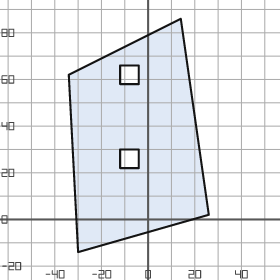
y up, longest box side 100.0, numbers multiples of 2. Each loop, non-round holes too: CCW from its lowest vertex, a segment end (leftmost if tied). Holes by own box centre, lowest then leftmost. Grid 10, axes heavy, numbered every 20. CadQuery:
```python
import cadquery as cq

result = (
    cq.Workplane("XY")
    .moveTo(-30.0, -14.0)
    .lineTo(26.0, 2.0)
    .lineTo(14.0, 86.0)
    .lineTo(-34.0, 62.0)
    .close()
    .moveTo(-12.0, 22.0)
    .lineTo(-4.0, 22.0)
    .lineTo(-4.0, 30.0)
    .lineTo(-12.0, 30.0)
    .close()
    .moveTo(-12.0, 58.0)
    .lineTo(-4.0, 58.0)
    .lineTo(-4.0, 66.0)
    .lineTo(-12.0, 66.0)
    .close()
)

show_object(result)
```